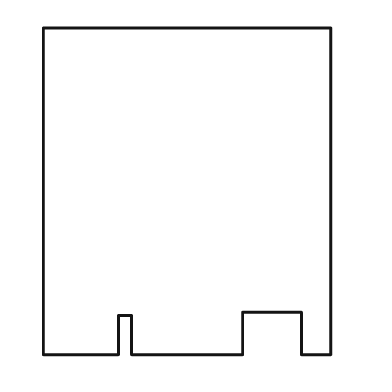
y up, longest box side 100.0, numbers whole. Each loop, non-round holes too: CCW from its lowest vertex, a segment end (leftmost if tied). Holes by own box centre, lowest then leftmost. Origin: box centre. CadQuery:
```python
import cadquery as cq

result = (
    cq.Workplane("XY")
    .moveTo(-44.0, -50.0)
    .lineTo(-21.0, -50.0)
    .lineTo(-21.0, -38.0)
    .lineTo(-17.0, -38.0)
    .lineTo(-17.0, -50.0)
    .lineTo(17.0, -50.0)
    .lineTo(17.0, -37.0)
    .lineTo(35.0, -37.0)
    .lineTo(35.0, -50.0)
    .lineTo(44.0, -50.0)
    .lineTo(44.0, 50.0)
    .lineTo(-44.0, 50.0)
    .close()
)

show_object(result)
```